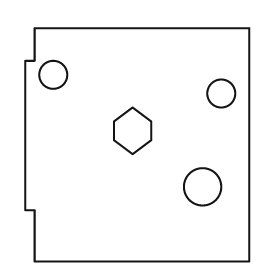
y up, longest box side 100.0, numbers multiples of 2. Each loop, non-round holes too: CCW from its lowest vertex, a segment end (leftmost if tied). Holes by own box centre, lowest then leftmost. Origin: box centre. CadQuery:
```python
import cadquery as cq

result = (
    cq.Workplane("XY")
    .moveTo(-44.0, -50.0)
    .lineTo(48.0, -50.0)
    .lineTo(48.0, 50.0)
    .lineTo(-44.0, 50.0)
    .lineTo(-44.0, 36.0)
    .lineTo(-48.0, 36.0)
    .lineTo(-48.0, -28.0)
    .lineTo(-44.0, -28.0)
    .close()
    .moveTo(28.0, -18.0)
    .circle(8.0)
    .moveTo(-2.0, -4.0)
    .lineTo(6.0, 2.0)
    .lineTo(6.0, 10.0)
    .lineTo(-2.0, 16.0)
    .lineTo(-10.0, 10.0)
    .lineTo(-10.0, 2.0)
    .close()
    .moveTo(36.0, 22.0)
    .circle(6.0)
    .moveTo(-36.0, 30.0)
    .circle(6.0)
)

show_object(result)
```